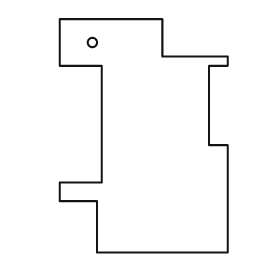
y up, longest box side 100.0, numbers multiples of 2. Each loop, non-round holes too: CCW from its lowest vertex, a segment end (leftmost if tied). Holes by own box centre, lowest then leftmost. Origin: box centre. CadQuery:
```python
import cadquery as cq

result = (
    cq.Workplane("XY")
    .moveTo(-20.0, -50.0)
    .lineTo(36.0, -50.0)
    .lineTo(36.0, -4.0)
    .lineTo(28.0, -4.0)
    .lineTo(28.0, 30.0)
    .lineTo(36.0, 30.0)
    .lineTo(36.0, 34.0)
    .lineTo(8.0, 34.0)
    .lineTo(8.0, 50.0)
    .lineTo(-36.0, 50.0)
    .lineTo(-36.0, 30.0)
    .lineTo(-18.0, 30.0)
    .lineTo(-18.0, -20.0)
    .lineTo(-36.0, -20.0)
    .lineTo(-36.0, -28.0)
    .lineTo(-20.0, -28.0)
    .close()
    .moveTo(-22.0, 40.0)
    .circle(2.0)
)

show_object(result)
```